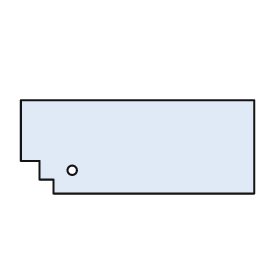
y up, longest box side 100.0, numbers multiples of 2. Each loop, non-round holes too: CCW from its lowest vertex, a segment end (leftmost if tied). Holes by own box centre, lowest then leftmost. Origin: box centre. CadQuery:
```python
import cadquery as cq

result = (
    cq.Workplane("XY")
    .moveTo(-36.0, -20.0)
    .lineTo(50.0, -20.0)
    .lineTo(50.0, 20.0)
    .lineTo(-50.0, 20.0)
    .lineTo(-50.0, -6.0)
    .lineTo(-42.0, -6.0)
    .lineTo(-42.0, -14.0)
    .lineTo(-36.0, -14.0)
    .close()
    .moveTo(-28.0, -10.0)
    .circle(2.0)
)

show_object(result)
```